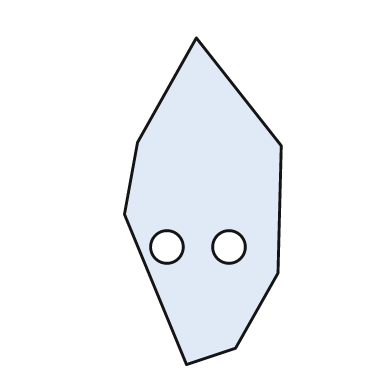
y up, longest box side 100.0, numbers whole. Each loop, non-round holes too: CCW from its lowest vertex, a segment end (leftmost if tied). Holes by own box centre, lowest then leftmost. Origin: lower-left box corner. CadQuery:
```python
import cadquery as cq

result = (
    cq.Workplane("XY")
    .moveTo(19.0, 0.0)
    .lineTo(34.0, 5.0)
    .lineTo(47.0, 28.0)
    .lineTo(48.0, 67.0)
    .lineTo(22.0, 100.0)
    .lineTo(4.0, 68.0)
    .lineTo(0.0, 46.0)
    .close()
    .moveTo(13.0, 36.0)
    .circle(5.0)
    .moveTo(32.0, 36.0)
    .circle(5.0)
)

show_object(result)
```